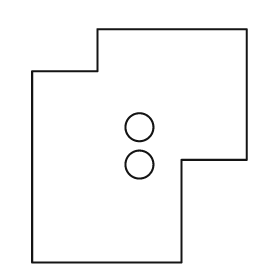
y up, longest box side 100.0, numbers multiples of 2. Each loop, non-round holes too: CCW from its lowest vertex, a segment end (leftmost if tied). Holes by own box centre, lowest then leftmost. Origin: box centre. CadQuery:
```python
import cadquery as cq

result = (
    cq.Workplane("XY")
    .moveTo(-46.0, -50.0)
    .lineTo(18.0, -50.0)
    .lineTo(18.0, -6.0)
    .lineTo(46.0, -6.0)
    .lineTo(46.0, 50.0)
    .lineTo(-18.0, 50.0)
    .lineTo(-18.0, 32.0)
    .lineTo(-46.0, 32.0)
    .close()
    .moveTo(0.0, -8.0)
    .circle(6.0)
    .moveTo(0.0, 8.0)
    .circle(6.0)
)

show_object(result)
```